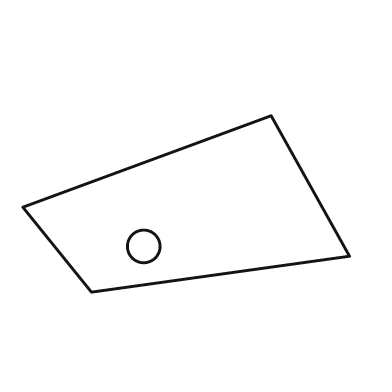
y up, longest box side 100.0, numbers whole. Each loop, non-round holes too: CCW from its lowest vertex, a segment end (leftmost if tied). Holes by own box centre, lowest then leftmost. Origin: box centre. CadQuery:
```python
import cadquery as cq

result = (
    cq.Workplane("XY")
    .moveTo(-29.0, -27.0)
    .lineTo(50.0, -16.0)
    .lineTo(26.0, 27.0)
    .lineTo(-50.0, -1.0)
    .close()
    .moveTo(-13.0, -13.0)
    .circle(5.0)
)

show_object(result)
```